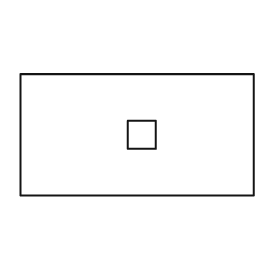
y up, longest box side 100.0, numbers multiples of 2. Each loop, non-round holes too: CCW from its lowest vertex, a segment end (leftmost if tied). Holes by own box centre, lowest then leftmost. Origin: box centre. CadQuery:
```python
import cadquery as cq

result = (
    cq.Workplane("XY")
    .moveTo(-50.0, -26.0)
    .lineTo(50.0, -26.0)
    .lineTo(50.0, 26.0)
    .lineTo(-50.0, 26.0)
    .close()
    .moveTo(-4.0, -6.0)
    .lineTo(8.0, -6.0)
    .lineTo(8.0, 6.0)
    .lineTo(-4.0, 6.0)
    .close()
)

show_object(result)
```